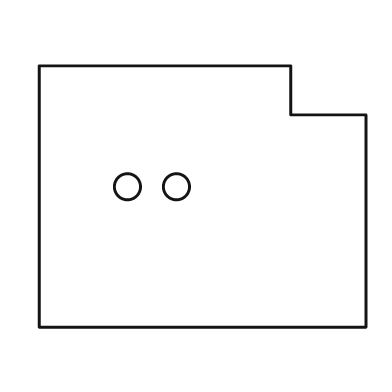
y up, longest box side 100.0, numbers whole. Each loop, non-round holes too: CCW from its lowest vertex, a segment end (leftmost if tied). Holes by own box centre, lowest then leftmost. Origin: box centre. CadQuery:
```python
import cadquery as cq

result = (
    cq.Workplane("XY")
    .moveTo(-50.0, -40.0)
    .lineTo(50.0, -40.0)
    .lineTo(50.0, 25.0)
    .lineTo(27.0, 25.0)
    .lineTo(27.0, 40.0)
    .lineTo(-50.0, 40.0)
    .close()
    .moveTo(-23.0, 3.0)
    .circle(4.0)
    .moveTo(-8.0, 3.0)
    .circle(4.0)
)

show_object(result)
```